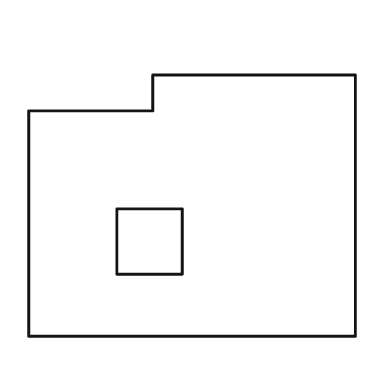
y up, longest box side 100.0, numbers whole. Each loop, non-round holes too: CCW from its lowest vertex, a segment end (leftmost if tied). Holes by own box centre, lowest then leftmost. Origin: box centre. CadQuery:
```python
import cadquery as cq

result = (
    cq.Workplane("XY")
    .moveTo(-50.0, -40.0)
    .lineTo(50.0, -40.0)
    .lineTo(50.0, 40.0)
    .lineTo(-12.0, 40.0)
    .lineTo(-12.0, 29.0)
    .lineTo(-50.0, 29.0)
    .close()
    .moveTo(-23.0, -21.0)
    .lineTo(-3.0, -21.0)
    .lineTo(-3.0, -1.0)
    .lineTo(-23.0, -1.0)
    .close()
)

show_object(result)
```